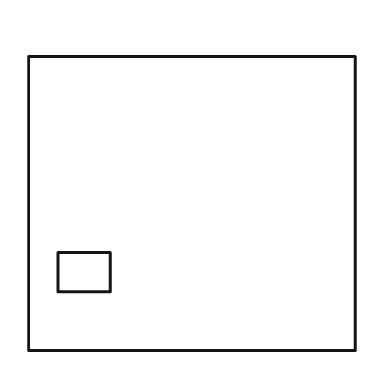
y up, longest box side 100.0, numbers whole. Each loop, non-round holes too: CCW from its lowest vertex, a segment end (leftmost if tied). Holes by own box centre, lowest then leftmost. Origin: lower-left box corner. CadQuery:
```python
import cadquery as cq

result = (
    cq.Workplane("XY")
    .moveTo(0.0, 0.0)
    .lineTo(100.0, 0.0)
    .lineTo(100.0, 90.0)
    .lineTo(0.0, 90.0)
    .close()
    .moveTo(9.0, 18.0)
    .lineTo(25.0, 18.0)
    .lineTo(25.0, 30.0)
    .lineTo(9.0, 30.0)
    .close()
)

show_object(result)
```